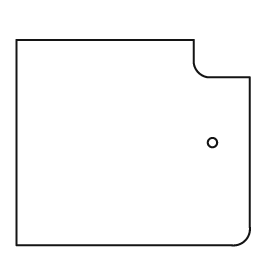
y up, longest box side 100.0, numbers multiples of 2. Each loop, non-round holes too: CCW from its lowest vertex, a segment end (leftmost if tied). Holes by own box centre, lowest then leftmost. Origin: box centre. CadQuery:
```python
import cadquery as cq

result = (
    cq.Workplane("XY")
    .moveTo(-50.0, -44.0)
    .lineTo(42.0, -44.0)
    .threePointArc((48.0, -42.0), (50.0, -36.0))
    .lineTo(50.0, 28.0)
    .lineTo(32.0, 28.0)
    .threePointArc((28.0, 30.0), (26.0, 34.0))
    .lineTo(26.0, 44.0)
    .lineTo(-50.0, 44.0)
    .close()
    .moveTo(34.0, 0.0)
    .circle(2.0)
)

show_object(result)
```